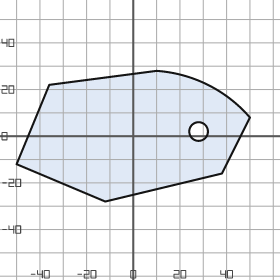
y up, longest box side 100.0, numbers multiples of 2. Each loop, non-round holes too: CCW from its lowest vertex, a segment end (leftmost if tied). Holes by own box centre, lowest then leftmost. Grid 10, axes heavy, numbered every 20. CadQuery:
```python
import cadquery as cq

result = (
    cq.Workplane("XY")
    .moveTo(-12.0, -28.0)
    .lineTo(38.0, -16.0)
    .lineTo(50.0, 8.0)
    .threePointArc((32.0, 22.0), (10.0, 28.0))
    .lineTo(-36.0, 22.0)
    .lineTo(-50.0, -12.0)
    .close()
    .moveTo(28.0, 2.0)
    .circle(4.0)
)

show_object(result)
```